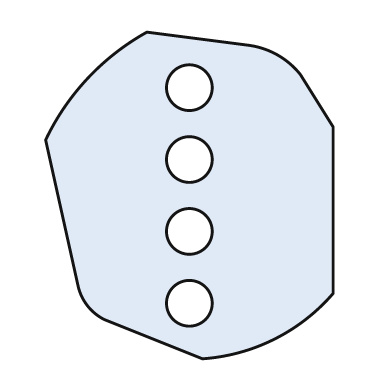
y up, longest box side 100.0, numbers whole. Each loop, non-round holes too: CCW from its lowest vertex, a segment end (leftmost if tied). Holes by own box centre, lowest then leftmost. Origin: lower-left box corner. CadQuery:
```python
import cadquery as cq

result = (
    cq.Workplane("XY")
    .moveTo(48.0, 0.0)
    .threePointArc((70.0, 6.0), (88.0, 20.0))
    .lineTo(88.0, 71.0)
    .lineTo(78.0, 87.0)
    .threePointArc((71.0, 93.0), (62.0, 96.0))
    .lineTo(31.0, 100.0)
    .threePointArc((13.0, 86.0), (0.0, 67.0))
    .lineTo(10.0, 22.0)
    .threePointArc((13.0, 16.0), (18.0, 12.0))
    .close()
    .moveTo(44.0, 17.0)
    .circle(7.0)
    .moveTo(44.0, 39.0)
    .circle(7.0)
    .moveTo(44.0, 61.0)
    .circle(7.0)
    .moveTo(44.0, 83.0)
    .circle(7.0)
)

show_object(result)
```